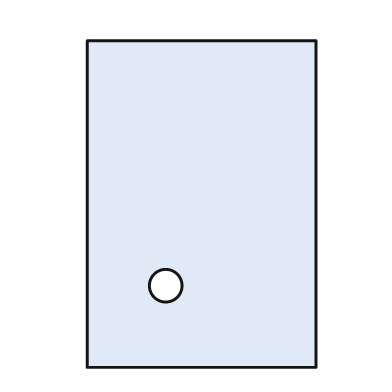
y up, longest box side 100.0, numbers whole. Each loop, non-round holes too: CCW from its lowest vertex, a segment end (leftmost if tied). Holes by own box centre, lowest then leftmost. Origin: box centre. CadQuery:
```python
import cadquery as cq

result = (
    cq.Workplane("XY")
    .moveTo(-35.0, -50.0)
    .lineTo(35.0, -50.0)
    .lineTo(35.0, 50.0)
    .lineTo(-35.0, 50.0)
    .close()
    .moveTo(-11.0, -25.0)
    .circle(5.0)
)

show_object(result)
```